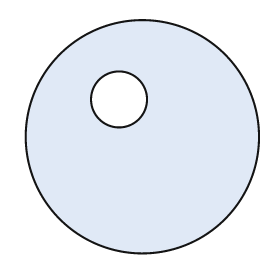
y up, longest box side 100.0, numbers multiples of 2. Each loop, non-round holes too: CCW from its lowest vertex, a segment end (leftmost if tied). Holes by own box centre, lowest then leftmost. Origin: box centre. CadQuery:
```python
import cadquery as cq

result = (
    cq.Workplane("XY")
    .moveTo(0.0, 0.0)
    .circle(50.0)
    .moveTo(-10.0, 16.0)
    .circle(12.0)
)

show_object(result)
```